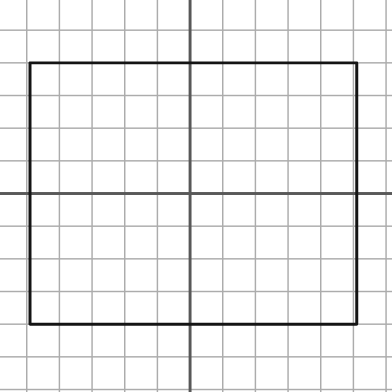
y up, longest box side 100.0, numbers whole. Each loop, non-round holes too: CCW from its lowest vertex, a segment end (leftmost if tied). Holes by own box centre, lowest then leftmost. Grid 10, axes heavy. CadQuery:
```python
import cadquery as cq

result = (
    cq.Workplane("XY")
    .moveTo(-49.0, -40.0)
    .lineTo(51.0, -40.0)
    .lineTo(51.0, 40.0)
    .lineTo(-49.0, 40.0)
    .close()
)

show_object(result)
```